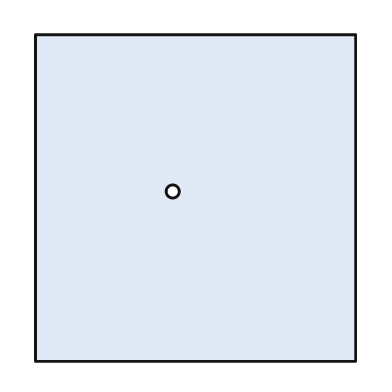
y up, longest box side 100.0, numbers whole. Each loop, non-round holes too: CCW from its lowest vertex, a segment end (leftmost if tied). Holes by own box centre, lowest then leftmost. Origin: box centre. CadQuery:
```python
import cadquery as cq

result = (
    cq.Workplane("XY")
    .moveTo(-49.0, -50.0)
    .lineTo(49.0, -50.0)
    .lineTo(49.0, 50.0)
    .lineTo(-49.0, 50.0)
    .close()
    .moveTo(-7.0, 2.0)
    .circle(2.0)
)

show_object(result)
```